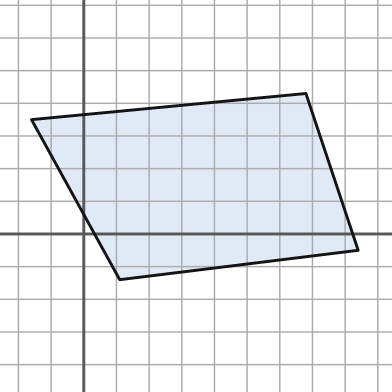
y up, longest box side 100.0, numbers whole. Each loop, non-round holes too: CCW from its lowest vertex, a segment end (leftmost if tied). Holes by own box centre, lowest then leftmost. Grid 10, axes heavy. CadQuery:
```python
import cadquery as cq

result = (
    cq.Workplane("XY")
    .moveTo(11.0, -14.0)
    .lineTo(84.0, -5.0)
    .lineTo(68.0, 43.0)
    .lineTo(-16.0, 35.0)
    .close()
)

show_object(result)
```